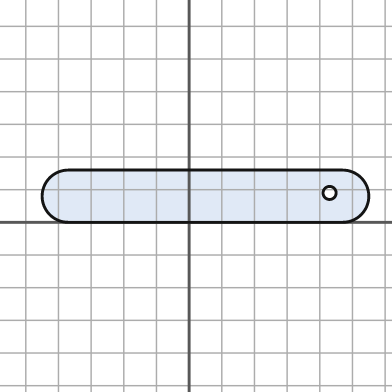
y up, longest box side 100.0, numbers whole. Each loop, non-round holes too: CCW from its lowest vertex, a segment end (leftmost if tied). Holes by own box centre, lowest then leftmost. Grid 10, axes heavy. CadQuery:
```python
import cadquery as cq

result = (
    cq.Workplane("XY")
    .moveTo(-37.0, 0.0)
    .lineTo(47.0, 0.0)
    .threePointArc((55.0, 8.0), (47.0, 16.0))
    .lineTo(-37.0, 16.0)
    .threePointArc((-45.0, 8.0), (-37.0, 0.0))
    .close()
    .moveTo(43.0, 9.0)
    .circle(2.0)
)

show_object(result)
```